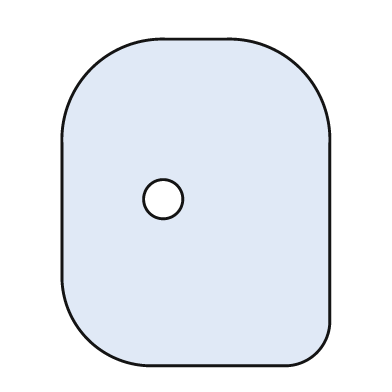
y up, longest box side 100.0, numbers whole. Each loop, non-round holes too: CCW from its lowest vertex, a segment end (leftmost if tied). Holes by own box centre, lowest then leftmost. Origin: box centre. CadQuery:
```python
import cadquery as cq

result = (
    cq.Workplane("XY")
    .moveTo(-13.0, -50.0)
    .lineTo(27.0, -50.0)
    .threePointArc((37.0, -46.0), (41.0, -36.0))
    .lineTo(41.0, 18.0)
    .threePointArc((32.0, 41.0), (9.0, 50.0))
    .lineTo(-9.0, 50.0)
    .threePointArc((-32.0, 41.0), (-41.0, 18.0))
    .lineTo(-41.0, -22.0)
    .threePointArc((-33.0, -42.0), (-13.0, -50.0))
    .close()
    .moveTo(-10.0, 1.0)
    .circle(6.0)
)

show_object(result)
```